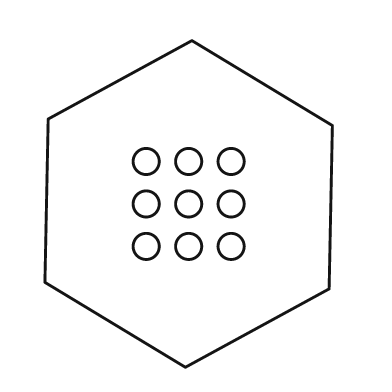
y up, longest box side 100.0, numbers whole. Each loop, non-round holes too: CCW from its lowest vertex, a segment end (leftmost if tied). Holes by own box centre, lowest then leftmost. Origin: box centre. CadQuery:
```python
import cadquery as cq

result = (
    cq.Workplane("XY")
    .moveTo(-1.0, -50.0)
    .lineTo(43.0, -26.0)
    .lineTo(44.0, 24.0)
    .lineTo(1.0, 50.0)
    .lineTo(-43.0, 26.0)
    .lineTo(-44.0, -24.0)
    .close()
    .moveTo(-13.0, -13.0)
    .circle(4.0)
    .moveTo(0.0, -13.0)
    .circle(4.0)
    .moveTo(13.0, -13.0)
    .circle(4.0)
    .moveTo(-13.0, 0.0)
    .circle(4.0)
    .moveTo(0.0, 0.0)
    .circle(4.0)
    .moveTo(13.0, 0.0)
    .circle(4.0)
    .moveTo(-13.0, 13.0)
    .circle(4.0)
    .moveTo(0.0, 13.0)
    .circle(4.0)
    .moveTo(13.0, 13.0)
    .circle(4.0)
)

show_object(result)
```